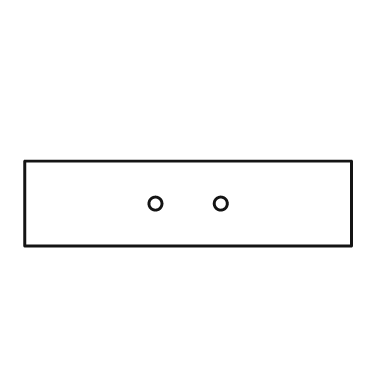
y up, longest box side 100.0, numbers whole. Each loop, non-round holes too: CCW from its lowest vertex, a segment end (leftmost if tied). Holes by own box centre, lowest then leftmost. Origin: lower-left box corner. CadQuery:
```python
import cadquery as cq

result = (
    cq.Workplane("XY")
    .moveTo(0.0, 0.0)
    .lineTo(100.0, 0.0)
    .lineTo(100.0, 26.0)
    .lineTo(0.0, 26.0)
    .close()
    .moveTo(40.0, 13.0)
    .circle(2.0)
    .moveTo(60.0, 13.0)
    .circle(2.0)
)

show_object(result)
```